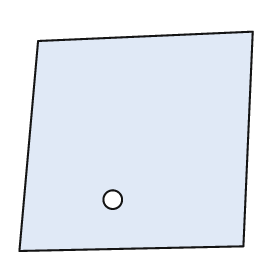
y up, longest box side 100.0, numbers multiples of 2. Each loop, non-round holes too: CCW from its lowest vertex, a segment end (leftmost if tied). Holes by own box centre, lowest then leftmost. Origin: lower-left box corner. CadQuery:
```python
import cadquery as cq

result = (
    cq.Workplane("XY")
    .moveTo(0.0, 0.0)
    .lineTo(96.0, 2.0)
    .lineTo(100.0, 94.0)
    .lineTo(8.0, 90.0)
    .close()
    .moveTo(40.0, 22.0)
    .circle(4.0)
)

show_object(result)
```